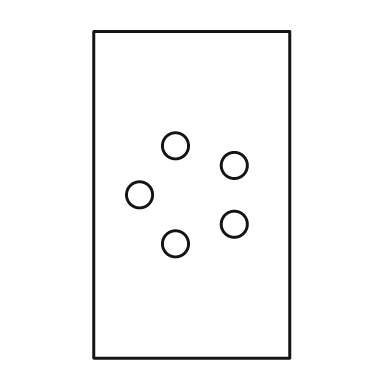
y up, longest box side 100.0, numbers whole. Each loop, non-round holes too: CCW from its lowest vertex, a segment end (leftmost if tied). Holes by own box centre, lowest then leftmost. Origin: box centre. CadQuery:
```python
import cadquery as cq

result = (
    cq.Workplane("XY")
    .moveTo(-30.0, -50.0)
    .lineTo(30.0, -50.0)
    .lineTo(30.0, 50.0)
    .lineTo(-30.0, 50.0)
    .close()
    .moveTo(-5.0, -15.0)
    .circle(4.0)
    .moveTo(13.0, -9.0)
    .circle(4.0)
    .moveTo(-16.0, 0.0)
    .circle(4.0)
    .moveTo(13.0, 9.0)
    .circle(4.0)
    .moveTo(-5.0, 15.0)
    .circle(4.0)
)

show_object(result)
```